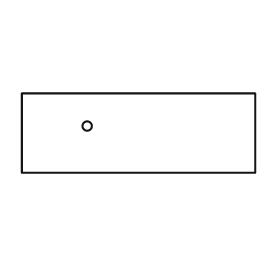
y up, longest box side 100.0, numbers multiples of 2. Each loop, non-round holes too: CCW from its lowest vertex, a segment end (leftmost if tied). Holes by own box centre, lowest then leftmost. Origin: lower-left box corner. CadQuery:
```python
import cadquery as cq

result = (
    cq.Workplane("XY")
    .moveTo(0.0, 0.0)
    .lineTo(100.0, 0.0)
    .lineTo(100.0, 34.0)
    .lineTo(0.0, 34.0)
    .close()
    .moveTo(28.0, 20.0)
    .circle(2.0)
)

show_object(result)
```